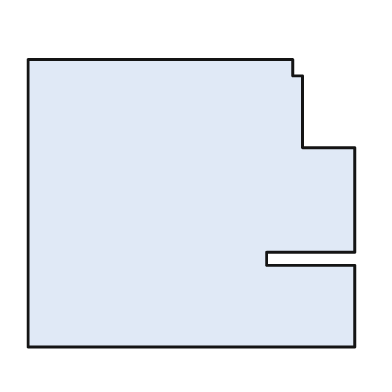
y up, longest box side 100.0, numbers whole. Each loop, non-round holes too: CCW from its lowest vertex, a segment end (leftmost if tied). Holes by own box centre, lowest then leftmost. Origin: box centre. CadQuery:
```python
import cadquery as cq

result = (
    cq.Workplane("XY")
    .moveTo(-50.0, -44.0)
    .lineTo(50.0, -44.0)
    .lineTo(50.0, -19.0)
    .lineTo(23.0, -19.0)
    .lineTo(23.0, -15.0)
    .lineTo(50.0, -15.0)
    .lineTo(50.0, 17.0)
    .lineTo(34.0, 17.0)
    .lineTo(34.0, 39.0)
    .lineTo(31.0, 39.0)
    .lineTo(31.0, 44.0)
    .lineTo(-50.0, 44.0)
    .close()
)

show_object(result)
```